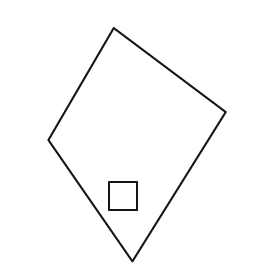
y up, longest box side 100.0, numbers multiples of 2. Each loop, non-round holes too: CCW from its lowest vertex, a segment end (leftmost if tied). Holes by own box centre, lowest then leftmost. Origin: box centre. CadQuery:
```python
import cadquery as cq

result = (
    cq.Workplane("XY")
    .moveTo(-2.0, -50.0)
    .lineTo(38.0, 14.0)
    .lineTo(-10.0, 50.0)
    .lineTo(-38.0, 2.0)
    .close()
    .moveTo(-12.0, -28.0)
    .lineTo(0.0, -28.0)
    .lineTo(0.0, -16.0)
    .lineTo(-12.0, -16.0)
    .close()
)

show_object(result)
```